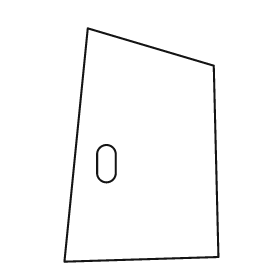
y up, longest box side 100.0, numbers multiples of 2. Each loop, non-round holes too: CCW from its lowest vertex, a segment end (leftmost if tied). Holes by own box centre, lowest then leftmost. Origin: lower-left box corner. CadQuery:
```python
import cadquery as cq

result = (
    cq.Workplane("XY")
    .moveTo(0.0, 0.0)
    .lineTo(66.0, 2.0)
    .lineTo(64.0, 84.0)
    .lineTo(10.0, 100.0)
    .close()
    .moveTo(14.0, 38.0)
    .threePointArc((18.0, 34.0), (22.0, 38.0))
    .lineTo(22.0, 46.0)
    .threePointArc((18.0, 50.0), (14.0, 46.0))
    .close()
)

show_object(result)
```